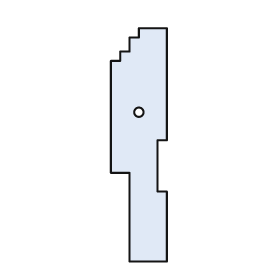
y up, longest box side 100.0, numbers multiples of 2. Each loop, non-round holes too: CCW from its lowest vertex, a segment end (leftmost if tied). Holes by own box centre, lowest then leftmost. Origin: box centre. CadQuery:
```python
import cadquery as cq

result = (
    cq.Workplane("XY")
    .moveTo(-4.0, -50.0)
    .lineTo(12.0, -50.0)
    .lineTo(12.0, -20.0)
    .lineTo(8.0, -20.0)
    .lineTo(8.0, 2.0)
    .lineTo(12.0, 2.0)
    .lineTo(12.0, 50.0)
    .lineTo(0.0, 50.0)
    .lineTo(0.0, 46.0)
    .lineTo(-4.0, 46.0)
    .lineTo(-4.0, 40.0)
    .lineTo(-8.0, 40.0)
    .lineTo(-8.0, 36.0)
    .lineTo(-12.0, 36.0)
    .lineTo(-12.0, -12.0)
    .lineTo(-4.0, -12.0)
    .close()
    .moveTo(0.0, 14.0)
    .circle(2.0)
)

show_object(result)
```